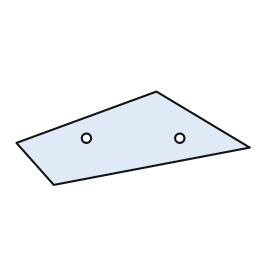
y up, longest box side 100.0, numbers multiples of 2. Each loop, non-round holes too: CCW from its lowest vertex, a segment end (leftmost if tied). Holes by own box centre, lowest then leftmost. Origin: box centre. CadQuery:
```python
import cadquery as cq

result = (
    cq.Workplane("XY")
    .moveTo(-34.0, -20.0)
    .lineTo(50.0, -4.0)
    .lineTo(10.0, 20.0)
    .lineTo(-50.0, -2.0)
    .close()
    .moveTo(-20.0, 0.0)
    .circle(2.0)
    .moveTo(20.0, 0.0)
    .circle(2.0)
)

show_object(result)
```